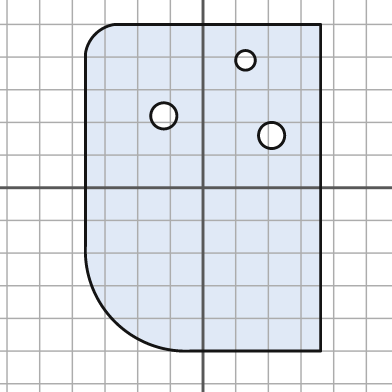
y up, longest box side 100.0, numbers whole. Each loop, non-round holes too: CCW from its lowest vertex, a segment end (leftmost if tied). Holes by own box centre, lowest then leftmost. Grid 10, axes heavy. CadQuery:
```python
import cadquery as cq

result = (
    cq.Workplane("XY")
    .moveTo(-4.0, -50.0)
    .lineTo(36.0, -50.0)
    .lineTo(36.0, 50.0)
    .lineTo(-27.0, 50.0)
    .threePointArc((-33.0, 47.0), (-36.0, 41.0))
    .lineTo(-36.0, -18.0)
    .threePointArc((-27.0, -41.0), (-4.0, -50.0))
    .close()
    .moveTo(21.0, 16.0)
    .circle(4.0)
    .moveTo(-12.0, 22.0)
    .circle(4.0)
    .moveTo(13.0, 39.0)
    .circle(3.0)
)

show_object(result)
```